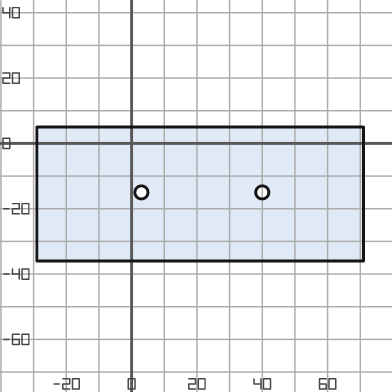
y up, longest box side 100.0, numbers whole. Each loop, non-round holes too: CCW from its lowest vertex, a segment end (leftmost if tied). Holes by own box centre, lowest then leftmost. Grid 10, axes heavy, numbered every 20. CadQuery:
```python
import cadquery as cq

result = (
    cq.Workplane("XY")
    .moveTo(-29.0, -36.0)
    .lineTo(71.0, -36.0)
    .lineTo(71.0, 5.0)
    .lineTo(-29.0, 5.0)
    .close()
    .moveTo(3.0, -15.0)
    .circle(2.0)
    .moveTo(40.0, -15.0)
    .circle(2.0)
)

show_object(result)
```